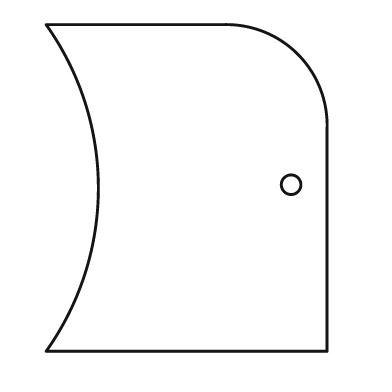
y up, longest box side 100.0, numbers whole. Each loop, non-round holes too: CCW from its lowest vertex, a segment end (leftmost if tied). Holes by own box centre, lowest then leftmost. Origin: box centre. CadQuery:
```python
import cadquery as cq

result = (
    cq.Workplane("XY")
    .moveTo(-43.0, -50.0)
    .lineTo(43.0, -50.0)
    .lineTo(43.0, 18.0)
    .threePointArc((34.0, 41.0), (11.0, 50.0))
    .lineTo(-43.0, 50.0)
    .threePointArc((-27.0, 0.0), (-43.0, -50.0))
    .close()
    .moveTo(32.0, 1.0)
    .circle(3.0)
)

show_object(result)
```